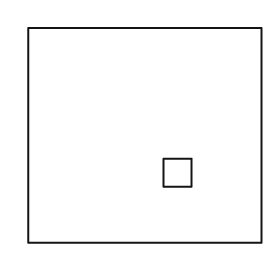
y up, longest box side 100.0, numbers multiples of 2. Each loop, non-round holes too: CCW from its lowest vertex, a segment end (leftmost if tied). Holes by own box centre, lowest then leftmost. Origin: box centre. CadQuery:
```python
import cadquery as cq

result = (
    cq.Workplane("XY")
    .moveTo(-50.0, -46.0)
    .lineTo(50.0, -46.0)
    .lineTo(50.0, 46.0)
    .lineTo(-50.0, 46.0)
    .close()
    .moveTo(8.0, -22.0)
    .lineTo(20.0, -22.0)
    .lineTo(20.0, -10.0)
    .lineTo(8.0, -10.0)
    .close()
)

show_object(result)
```